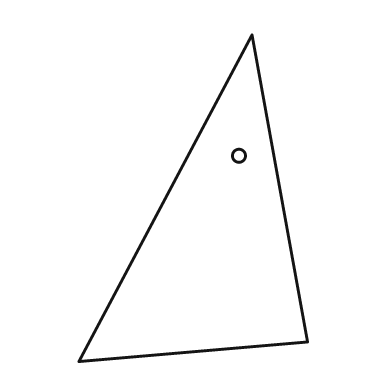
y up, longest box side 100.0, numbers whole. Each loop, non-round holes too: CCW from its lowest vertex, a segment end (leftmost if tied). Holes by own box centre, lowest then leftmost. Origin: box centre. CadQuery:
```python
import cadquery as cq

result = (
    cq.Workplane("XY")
    .moveTo(-35.0, -50.0)
    .lineTo(35.0, -44.0)
    .lineTo(18.0, 50.0)
    .close()
    .moveTo(14.0, 13.0)
    .circle(2.0)
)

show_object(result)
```